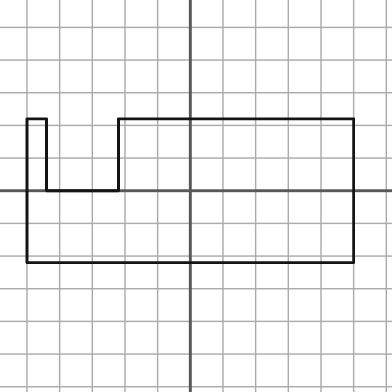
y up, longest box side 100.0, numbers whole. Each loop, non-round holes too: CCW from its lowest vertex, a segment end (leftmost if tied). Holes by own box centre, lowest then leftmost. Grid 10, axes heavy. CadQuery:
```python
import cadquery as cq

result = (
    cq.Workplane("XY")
    .moveTo(-50.0, -22.0)
    .lineTo(50.0, -22.0)
    .lineTo(50.0, 22.0)
    .lineTo(-22.0, 22.0)
    .lineTo(-22.0, 0.0)
    .lineTo(-44.0, 0.0)
    .lineTo(-44.0, 22.0)
    .lineTo(-50.0, 22.0)
    .close()
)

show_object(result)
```